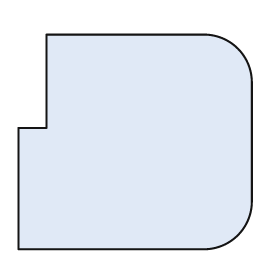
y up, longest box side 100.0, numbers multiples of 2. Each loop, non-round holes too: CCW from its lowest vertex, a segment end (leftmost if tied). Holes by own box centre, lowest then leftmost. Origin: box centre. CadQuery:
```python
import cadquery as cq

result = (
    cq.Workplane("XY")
    .moveTo(-50.0, -46.0)
    .lineTo(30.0, -46.0)
    .threePointArc((44.0, -40.0), (50.0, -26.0))
    .lineTo(50.0, 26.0)
    .threePointArc((44.0, 40.0), (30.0, 46.0))
    .lineTo(-38.0, 46.0)
    .lineTo(-38.0, 6.0)
    .lineTo(-50.0, 6.0)
    .close()
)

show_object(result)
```